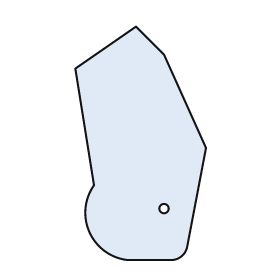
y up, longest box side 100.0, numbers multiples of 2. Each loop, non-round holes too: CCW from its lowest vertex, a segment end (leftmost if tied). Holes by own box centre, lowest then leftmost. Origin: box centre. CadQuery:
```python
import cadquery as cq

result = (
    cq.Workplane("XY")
    .moveTo(-6.0, -50.0)
    .lineTo(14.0, -50.0)
    .threePointArc((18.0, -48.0), (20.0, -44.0))
    .lineTo(28.0, -2.0)
    .lineTo(10.0, 38.0)
    .lineTo(-2.0, 50.0)
    .lineTo(-28.0, 32.0)
    .lineTo(-20.0, -18.0)
    .threePointArc((-22.0, -38.0), (-6.0, -50.0))
    .close()
    .moveTo(10.0, -28.0)
    .circle(2.0)
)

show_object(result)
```